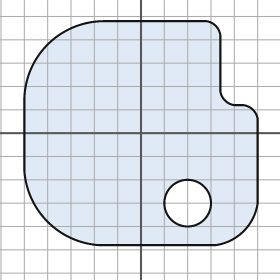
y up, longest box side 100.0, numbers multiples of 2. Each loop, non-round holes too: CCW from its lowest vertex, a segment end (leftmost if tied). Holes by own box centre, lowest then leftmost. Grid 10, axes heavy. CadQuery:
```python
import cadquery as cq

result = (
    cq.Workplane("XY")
    .moveTo(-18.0, -48.0)
    .lineTo(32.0, -48.0)
    .threePointArc((44.0, -42.0), (50.0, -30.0))
    .lineTo(50.0, 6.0)
    .threePointArc((48.0, 10.0), (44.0, 12.0))
    .lineTo(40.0, 12.0)
    .threePointArc((36.0, 14.0), (34.0, 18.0))
    .lineTo(34.0, 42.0)
    .threePointArc((32.0, 46.0), (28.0, 48.0))
    .lineTo(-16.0, 48.0)
    .threePointArc((-40.0, 38.0), (-50.0, 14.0))
    .lineTo(-50.0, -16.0)
    .threePointArc((-40.0, -38.0), (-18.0, -48.0))
    .close()
    .moveTo(20.0, -30.0)
    .circle(10.0)
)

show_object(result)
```